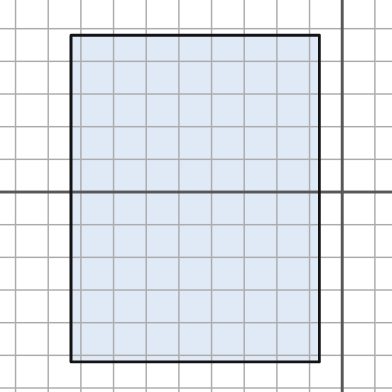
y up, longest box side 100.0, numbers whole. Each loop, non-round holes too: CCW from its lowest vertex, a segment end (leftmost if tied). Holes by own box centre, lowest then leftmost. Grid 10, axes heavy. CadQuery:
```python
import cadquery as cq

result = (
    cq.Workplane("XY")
    .moveTo(-83.0, -52.0)
    .lineTo(-7.0, -52.0)
    .lineTo(-7.0, 48.0)
    .lineTo(-83.0, 48.0)
    .close()
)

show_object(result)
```